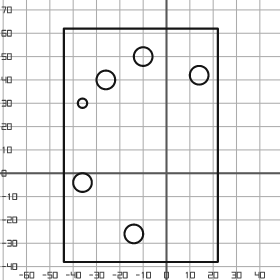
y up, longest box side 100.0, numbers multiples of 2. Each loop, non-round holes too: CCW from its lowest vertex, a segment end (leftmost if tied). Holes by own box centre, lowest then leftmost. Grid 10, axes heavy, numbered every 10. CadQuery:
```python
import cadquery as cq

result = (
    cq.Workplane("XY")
    .moveTo(-44.0, -38.0)
    .lineTo(22.0, -38.0)
    .lineTo(22.0, 62.0)
    .lineTo(-44.0, 62.0)
    .close()
    .moveTo(-14.0, -26.0)
    .circle(4.0)
    .moveTo(-36.0, -4.0)
    .circle(4.0)
    .moveTo(-36.0, 30.0)
    .circle(2.0)
    .moveTo(-26.0, 40.0)
    .circle(4.0)
    .moveTo(14.0, 42.0)
    .circle(4.0)
    .moveTo(-10.0, 50.0)
    .circle(4.0)
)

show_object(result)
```